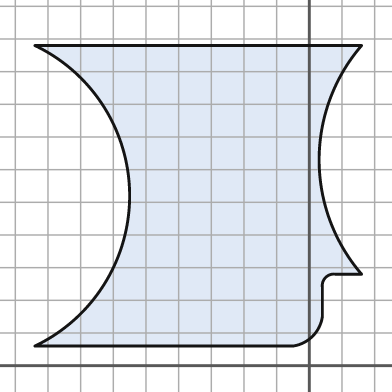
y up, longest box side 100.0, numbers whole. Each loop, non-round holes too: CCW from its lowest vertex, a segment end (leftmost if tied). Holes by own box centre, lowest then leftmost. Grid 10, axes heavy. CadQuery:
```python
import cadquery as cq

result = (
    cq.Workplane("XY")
    .moveTo(-84.0, 6.0)
    .lineTo(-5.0, 6.0)
    .threePointArc((1.0, 9.0), (4.0, 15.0))
    .lineTo(4.0, 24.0)
    .threePointArc((5.0, 27.0), (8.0, 28.0))
    .lineTo(16.0, 28.0)
    .threePointArc((3.0, 63.0), (16.0, 98.0))
    .lineTo(-84.0, 98.0)
    .threePointArc((-55.0, 52.0), (-84.0, 6.0))
    .close()
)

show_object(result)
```